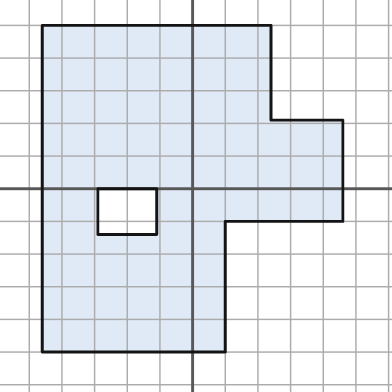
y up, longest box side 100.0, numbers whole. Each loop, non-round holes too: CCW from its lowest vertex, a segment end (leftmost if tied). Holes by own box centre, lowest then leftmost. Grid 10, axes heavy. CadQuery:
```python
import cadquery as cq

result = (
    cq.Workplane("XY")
    .moveTo(-46.0, -50.0)
    .lineTo(10.0, -50.0)
    .lineTo(10.0, -10.0)
    .lineTo(46.0, -10.0)
    .lineTo(46.0, 21.0)
    .lineTo(24.0, 21.0)
    .lineTo(24.0, 50.0)
    .lineTo(-46.0, 50.0)
    .close()
    .moveTo(-29.0, -14.0)
    .lineTo(-11.0, -14.0)
    .lineTo(-11.0, 0.0)
    .lineTo(-29.0, 0.0)
    .close()
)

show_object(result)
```